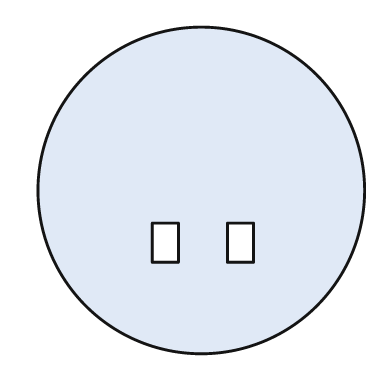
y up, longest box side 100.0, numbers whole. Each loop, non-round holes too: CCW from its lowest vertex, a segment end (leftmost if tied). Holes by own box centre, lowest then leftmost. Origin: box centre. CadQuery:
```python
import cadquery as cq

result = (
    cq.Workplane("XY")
    .moveTo(0.0, 0.0)
    .circle(50.0)
    .moveTo(-15.0, -22.0)
    .lineTo(-7.0, -22.0)
    .lineTo(-7.0, -10.0)
    .lineTo(-15.0, -10.0)
    .close()
    .moveTo(8.0, -22.0)
    .lineTo(16.0, -22.0)
    .lineTo(16.0, -10.0)
    .lineTo(8.0, -10.0)
    .close()
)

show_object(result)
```